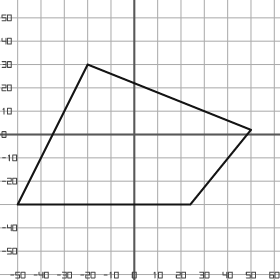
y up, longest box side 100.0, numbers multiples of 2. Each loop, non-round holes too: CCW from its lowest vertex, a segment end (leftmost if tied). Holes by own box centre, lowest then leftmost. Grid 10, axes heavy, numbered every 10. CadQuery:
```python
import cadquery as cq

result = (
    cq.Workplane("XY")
    .moveTo(-50.0, -30.0)
    .lineTo(24.0, -30.0)
    .lineTo(50.0, 2.0)
    .lineTo(-20.0, 30.0)
    .close()
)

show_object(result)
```